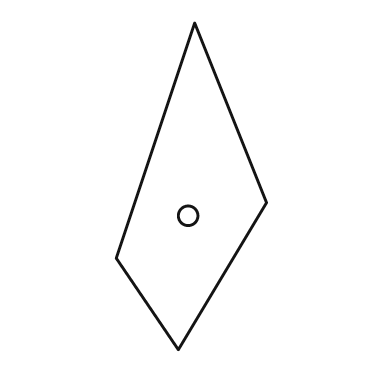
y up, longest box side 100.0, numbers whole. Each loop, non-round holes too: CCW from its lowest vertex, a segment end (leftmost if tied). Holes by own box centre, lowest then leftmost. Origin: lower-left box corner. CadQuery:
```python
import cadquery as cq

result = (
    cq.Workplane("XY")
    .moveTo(19.0, 0.0)
    .lineTo(46.0, 45.0)
    .lineTo(24.0, 100.0)
    .lineTo(0.0, 28.0)
    .close()
    .moveTo(22.0, 41.0)
    .circle(3.0)
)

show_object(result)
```